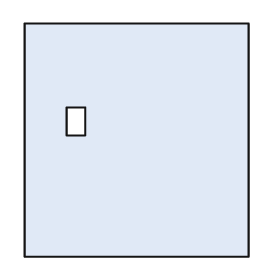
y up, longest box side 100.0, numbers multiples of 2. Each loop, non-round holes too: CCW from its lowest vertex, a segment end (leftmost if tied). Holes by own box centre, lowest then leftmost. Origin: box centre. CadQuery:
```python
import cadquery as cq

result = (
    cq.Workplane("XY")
    .moveTo(-48.0, -50.0)
    .lineTo(48.0, -50.0)
    .lineTo(48.0, 50.0)
    .lineTo(-48.0, 50.0)
    .close()
    .moveTo(-30.0, 2.0)
    .lineTo(-22.0, 2.0)
    .lineTo(-22.0, 14.0)
    .lineTo(-30.0, 14.0)
    .close()
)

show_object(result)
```